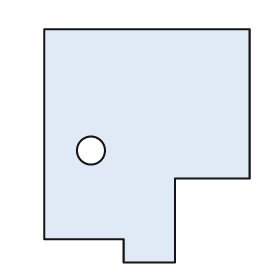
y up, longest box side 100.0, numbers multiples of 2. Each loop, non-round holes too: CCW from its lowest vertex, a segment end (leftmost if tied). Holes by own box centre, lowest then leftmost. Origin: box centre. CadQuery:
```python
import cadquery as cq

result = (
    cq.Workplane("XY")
    .moveTo(-10.0, -50.0)
    .lineTo(12.0, -50.0)
    .lineTo(12.0, -14.0)
    .lineTo(44.0, -14.0)
    .lineTo(44.0, 50.0)
    .lineTo(-44.0, 50.0)
    .lineTo(-44.0, -40.0)
    .lineTo(-10.0, -40.0)
    .close()
    .moveTo(-24.0, -2.0)
    .circle(6.0)
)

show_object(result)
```